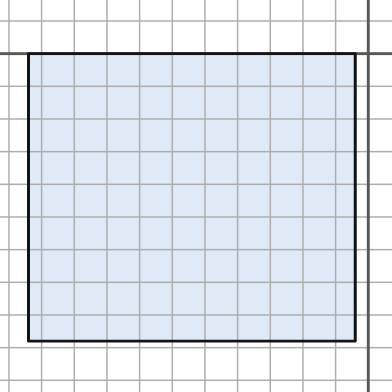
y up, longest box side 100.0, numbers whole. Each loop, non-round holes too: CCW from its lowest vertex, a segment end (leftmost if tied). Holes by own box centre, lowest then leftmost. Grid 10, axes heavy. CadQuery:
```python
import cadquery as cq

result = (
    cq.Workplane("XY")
    .moveTo(-104.0, -88.0)
    .lineTo(-4.0, -88.0)
    .lineTo(-4.0, 0.0)
    .lineTo(-104.0, 0.0)
    .close()
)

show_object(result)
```